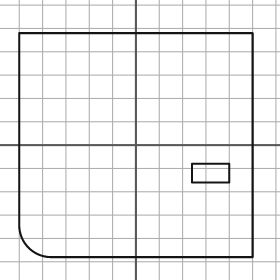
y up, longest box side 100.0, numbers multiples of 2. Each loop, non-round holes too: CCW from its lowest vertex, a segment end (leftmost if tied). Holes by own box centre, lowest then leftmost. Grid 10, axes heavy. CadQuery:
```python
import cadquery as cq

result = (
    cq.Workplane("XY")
    .moveTo(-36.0, -48.0)
    .lineTo(50.0, -48.0)
    .lineTo(50.0, 48.0)
    .lineTo(-50.0, 48.0)
    .lineTo(-50.0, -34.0)
    .threePointArc((-46.0, -44.0), (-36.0, -48.0))
    .close()
    .moveTo(24.0, -16.0)
    .lineTo(40.0, -16.0)
    .lineTo(40.0, -8.0)
    .lineTo(24.0, -8.0)
    .close()
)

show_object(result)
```